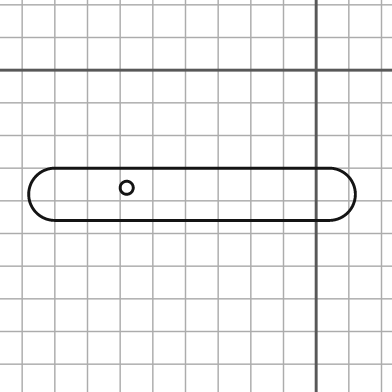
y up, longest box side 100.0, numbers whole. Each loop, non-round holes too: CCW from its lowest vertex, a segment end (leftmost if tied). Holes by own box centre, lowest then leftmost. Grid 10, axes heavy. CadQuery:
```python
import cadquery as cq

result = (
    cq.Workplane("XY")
    .moveTo(-80.0, -46.0)
    .lineTo(4.0, -46.0)
    .threePointArc((12.0, -38.0), (4.0, -30.0))
    .lineTo(-80.0, -30.0)
    .threePointArc((-88.0, -38.0), (-80.0, -46.0))
    .close()
    .moveTo(-58.0, -36.0)
    .circle(2.0)
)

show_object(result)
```